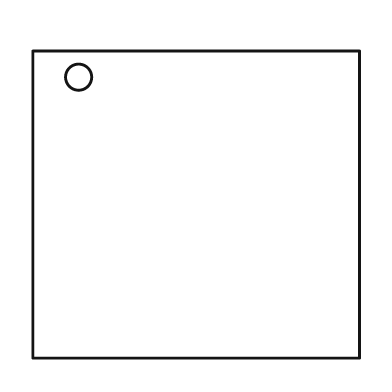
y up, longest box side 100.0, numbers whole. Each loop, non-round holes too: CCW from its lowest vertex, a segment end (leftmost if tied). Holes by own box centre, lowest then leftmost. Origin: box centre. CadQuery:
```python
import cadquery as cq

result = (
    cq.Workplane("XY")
    .moveTo(-50.0, -47.0)
    .lineTo(50.0, -47.0)
    .lineTo(50.0, 47.0)
    .lineTo(-50.0, 47.0)
    .close()
    .moveTo(-36.0, 39.0)
    .circle(4.0)
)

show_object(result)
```